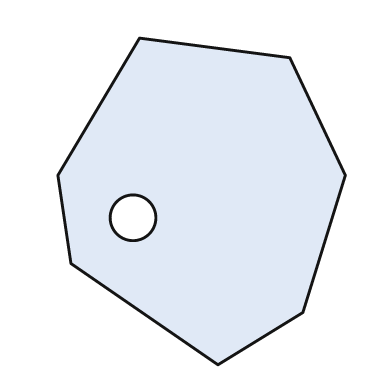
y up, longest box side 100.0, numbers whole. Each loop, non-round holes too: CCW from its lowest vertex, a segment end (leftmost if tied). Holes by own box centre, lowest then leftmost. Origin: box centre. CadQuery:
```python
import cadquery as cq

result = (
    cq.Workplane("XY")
    .moveTo(5.0, -50.0)
    .lineTo(31.0, -34.0)
    .lineTo(44.0, 8.0)
    .lineTo(27.0, 44.0)
    .lineTo(-19.0, 50.0)
    .lineTo(-44.0, 8.0)
    .lineTo(-40.0, -19.0)
    .close()
    .moveTo(-21.0, -5.0)
    .circle(7.0)
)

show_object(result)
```